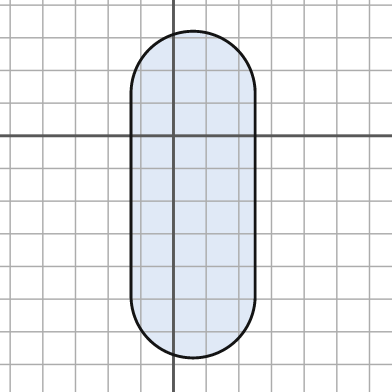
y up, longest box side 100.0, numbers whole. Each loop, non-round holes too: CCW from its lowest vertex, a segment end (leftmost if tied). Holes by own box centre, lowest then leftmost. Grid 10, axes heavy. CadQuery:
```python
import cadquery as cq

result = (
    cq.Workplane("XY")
    .moveTo(-13.0, -49.0)
    .threePointArc((6.0, -68.0), (25.0, -49.0))
    .lineTo(25.0, 13.0)
    .threePointArc((6.0, 32.0), (-13.0, 13.0))
    .close()
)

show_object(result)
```